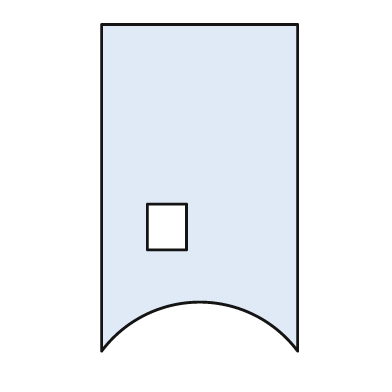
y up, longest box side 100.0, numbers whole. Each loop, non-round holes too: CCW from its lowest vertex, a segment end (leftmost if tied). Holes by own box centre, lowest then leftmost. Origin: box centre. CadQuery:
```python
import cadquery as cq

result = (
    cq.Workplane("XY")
    .moveTo(-30.0, -50.0)
    .threePointArc((0.0, -35.0), (30.0, -50.0))
    .lineTo(30.0, 50.0)
    .lineTo(-30.0, 50.0)
    .close()
    .moveTo(-16.0, -19.0)
    .lineTo(-4.0, -19.0)
    .lineTo(-4.0, -5.0)
    .lineTo(-16.0, -5.0)
    .close()
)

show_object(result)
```